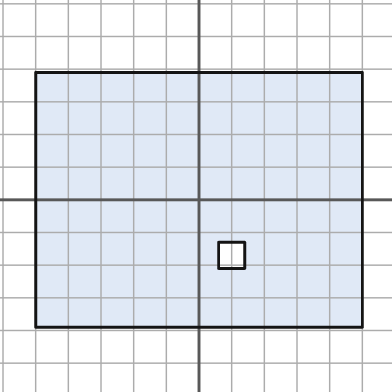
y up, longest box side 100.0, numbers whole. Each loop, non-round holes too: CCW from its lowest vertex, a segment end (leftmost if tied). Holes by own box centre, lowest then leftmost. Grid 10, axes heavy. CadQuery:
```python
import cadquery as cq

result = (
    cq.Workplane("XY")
    .moveTo(-50.0, -39.0)
    .lineTo(50.0, -39.0)
    .lineTo(50.0, 39.0)
    .lineTo(-50.0, 39.0)
    .close()
    .moveTo(6.0, -21.0)
    .lineTo(14.0, -21.0)
    .lineTo(14.0, -13.0)
    .lineTo(6.0, -13.0)
    .close()
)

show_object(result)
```